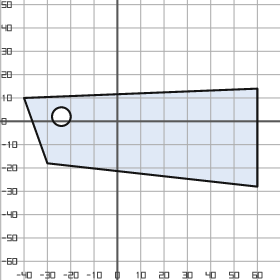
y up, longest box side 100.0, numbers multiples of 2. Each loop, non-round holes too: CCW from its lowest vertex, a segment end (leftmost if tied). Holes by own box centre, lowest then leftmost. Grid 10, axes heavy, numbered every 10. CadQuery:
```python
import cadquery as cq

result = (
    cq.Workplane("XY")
    .moveTo(60.0, -28.0)
    .lineTo(60.0, 14.0)
    .lineTo(-40.0, 10.0)
    .lineTo(-30.0, -18.0)
    .close()
    .moveTo(-24.0, 2.0)
    .circle(4.0)
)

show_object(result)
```